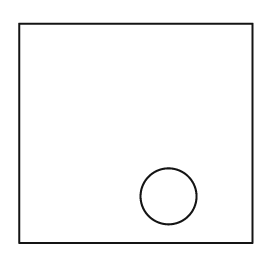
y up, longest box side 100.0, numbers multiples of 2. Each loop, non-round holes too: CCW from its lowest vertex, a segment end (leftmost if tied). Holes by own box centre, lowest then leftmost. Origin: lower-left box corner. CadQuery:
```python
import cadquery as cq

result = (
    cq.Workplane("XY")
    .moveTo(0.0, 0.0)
    .lineTo(100.0, 0.0)
    .lineTo(100.0, 94.0)
    .lineTo(0.0, 94.0)
    .close()
    .moveTo(64.0, 20.0)
    .circle(12.0)
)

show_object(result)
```